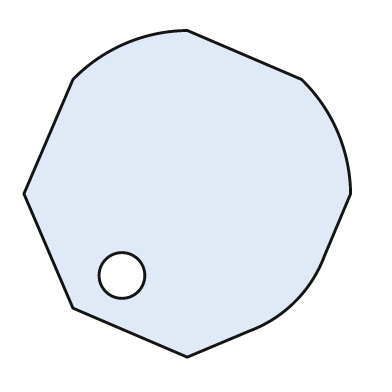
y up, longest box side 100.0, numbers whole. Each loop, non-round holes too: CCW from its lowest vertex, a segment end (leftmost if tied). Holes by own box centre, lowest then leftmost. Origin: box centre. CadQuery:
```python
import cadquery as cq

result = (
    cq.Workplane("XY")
    .moveTo(0.0, -50.0)
    .lineTo(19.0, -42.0)
    .threePointArc((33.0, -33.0), (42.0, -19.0))
    .lineTo(50.0, 0.0)
    .threePointArc((46.0, 19.0), (35.0, 35.0))
    .lineTo(0.0, 50.0)
    .threePointArc((-19.0, 46.0), (-35.0, 35.0))
    .lineTo(-50.0, 0.0)
    .lineTo(-35.0, -35.0)
    .close()
    .moveTo(-20.0, -25.0)
    .circle(7.0)
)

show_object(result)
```